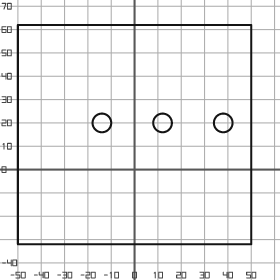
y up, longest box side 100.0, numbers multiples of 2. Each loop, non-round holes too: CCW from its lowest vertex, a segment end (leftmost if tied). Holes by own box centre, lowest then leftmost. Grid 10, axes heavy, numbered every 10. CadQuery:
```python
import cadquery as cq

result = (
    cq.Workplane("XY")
    .moveTo(-50.0, -32.0)
    .lineTo(50.0, -32.0)
    .lineTo(50.0, 62.0)
    .lineTo(-50.0, 62.0)
    .close()
    .moveTo(-14.0, 20.0)
    .circle(4.0)
    .moveTo(12.0, 20.0)
    .circle(4.0)
    .moveTo(38.0, 20.0)
    .circle(4.0)
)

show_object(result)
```